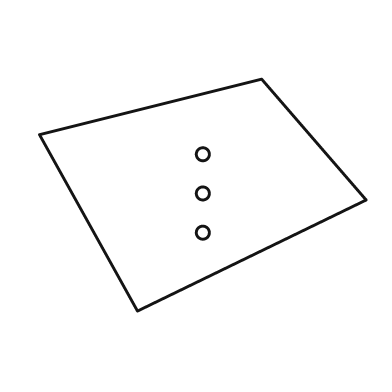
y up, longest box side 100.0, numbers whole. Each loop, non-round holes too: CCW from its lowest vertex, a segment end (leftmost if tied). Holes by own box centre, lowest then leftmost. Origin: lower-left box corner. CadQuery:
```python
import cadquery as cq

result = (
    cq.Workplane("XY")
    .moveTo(30.0, 0.0)
    .lineTo(100.0, 34.0)
    .lineTo(68.0, 71.0)
    .lineTo(0.0, 54.0)
    .close()
    .moveTo(50.0, 24.0)
    .circle(2.0)
    .moveTo(50.0, 36.0)
    .circle(2.0)
    .moveTo(50.0, 48.0)
    .circle(2.0)
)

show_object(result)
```